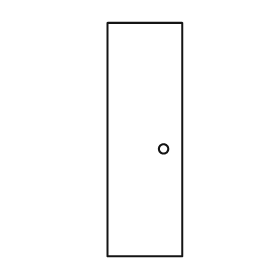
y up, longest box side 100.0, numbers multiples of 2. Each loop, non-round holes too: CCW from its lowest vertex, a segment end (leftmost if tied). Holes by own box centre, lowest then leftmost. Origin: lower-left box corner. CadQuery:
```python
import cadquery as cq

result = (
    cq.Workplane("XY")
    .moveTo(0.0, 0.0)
    .lineTo(32.0, 0.0)
    .lineTo(32.0, 100.0)
    .lineTo(0.0, 100.0)
    .close()
    .moveTo(24.0, 46.0)
    .circle(2.0)
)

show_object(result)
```